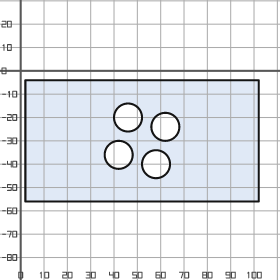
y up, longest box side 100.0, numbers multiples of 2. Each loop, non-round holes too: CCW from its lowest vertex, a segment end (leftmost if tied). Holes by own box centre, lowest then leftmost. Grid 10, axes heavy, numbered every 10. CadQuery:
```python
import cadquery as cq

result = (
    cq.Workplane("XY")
    .moveTo(2.0, -56.0)
    .lineTo(102.0, -56.0)
    .lineTo(102.0, -4.0)
    .lineTo(2.0, -4.0)
    .close()
    .moveTo(58.0, -40.0)
    .circle(6.0)
    .moveTo(42.0, -36.0)
    .circle(6.0)
    .moveTo(62.0, -24.0)
    .circle(6.0)
    .moveTo(46.0, -20.0)
    .circle(6.0)
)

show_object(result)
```